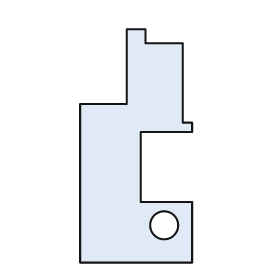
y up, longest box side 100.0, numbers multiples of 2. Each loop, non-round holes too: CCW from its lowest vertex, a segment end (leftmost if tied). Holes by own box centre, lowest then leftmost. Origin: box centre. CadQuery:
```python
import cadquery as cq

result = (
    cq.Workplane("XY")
    .moveTo(-24.0, -50.0)
    .lineTo(24.0, -50.0)
    .lineTo(24.0, -24.0)
    .lineTo(2.0, -24.0)
    .lineTo(2.0, 6.0)
    .lineTo(24.0, 6.0)
    .lineTo(24.0, 10.0)
    .lineTo(20.0, 10.0)
    .lineTo(20.0, 44.0)
    .lineTo(4.0, 44.0)
    .lineTo(4.0, 50.0)
    .lineTo(-4.0, 50.0)
    .lineTo(-4.0, 18.0)
    .lineTo(-24.0, 18.0)
    .close()
    .moveTo(12.0, -34.0)
    .circle(6.0)
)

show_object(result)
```